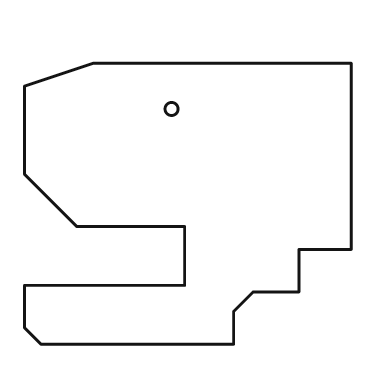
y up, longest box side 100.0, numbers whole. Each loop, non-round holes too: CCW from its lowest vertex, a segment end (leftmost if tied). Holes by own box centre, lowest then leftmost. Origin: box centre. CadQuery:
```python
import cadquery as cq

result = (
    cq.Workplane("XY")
    .moveTo(-45.0, -43.0)
    .lineTo(14.0, -43.0)
    .lineTo(14.0, -33.0)
    .lineTo(20.0, -27.0)
    .lineTo(34.0, -27.0)
    .lineTo(34.0, -14.0)
    .lineTo(50.0, -14.0)
    .lineTo(50.0, 43.0)
    .lineTo(-29.0, 43.0)
    .lineTo(-50.0, 36.0)
    .lineTo(-50.0, 9.0)
    .lineTo(-34.0, -7.0)
    .lineTo(-1.0, -7.0)
    .lineTo(-1.0, -25.0)
    .lineTo(-50.0, -25.0)
    .lineTo(-50.0, -38.0)
    .close()
    .moveTo(-5.0, 29.0)
    .circle(2.0)
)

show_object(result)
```